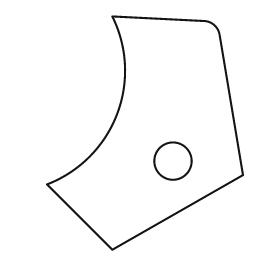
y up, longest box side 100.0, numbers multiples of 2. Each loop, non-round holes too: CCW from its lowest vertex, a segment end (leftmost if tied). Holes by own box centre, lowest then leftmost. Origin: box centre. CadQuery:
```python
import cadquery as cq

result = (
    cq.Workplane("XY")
    .moveTo(-14.0, -50.0)
    .lineTo(42.0, -18.0)
    .lineTo(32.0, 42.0)
    .threePointArc((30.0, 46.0), (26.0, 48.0))
    .lineTo(-14.0, 50.0)
    .threePointArc((-12.0, 8.0), (-42.0, -22.0))
    .close()
    .moveTo(12.0, -12.0)
    .circle(8.0)
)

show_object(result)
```